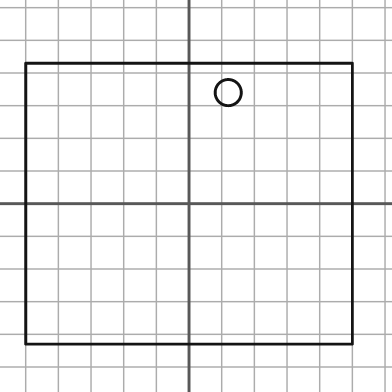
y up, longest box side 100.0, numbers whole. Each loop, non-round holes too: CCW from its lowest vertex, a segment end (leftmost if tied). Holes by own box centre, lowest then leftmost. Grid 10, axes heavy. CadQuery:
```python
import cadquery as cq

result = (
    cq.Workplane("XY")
    .moveTo(-50.0, -43.0)
    .lineTo(50.0, -43.0)
    .lineTo(50.0, 43.0)
    .lineTo(-50.0, 43.0)
    .close()
    .moveTo(12.0, 34.0)
    .circle(4.0)
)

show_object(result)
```